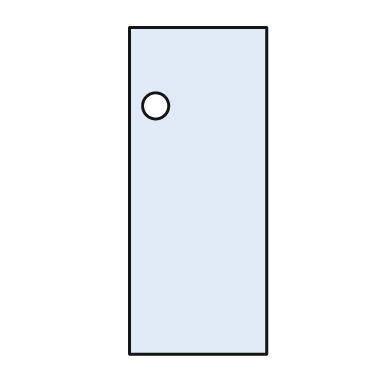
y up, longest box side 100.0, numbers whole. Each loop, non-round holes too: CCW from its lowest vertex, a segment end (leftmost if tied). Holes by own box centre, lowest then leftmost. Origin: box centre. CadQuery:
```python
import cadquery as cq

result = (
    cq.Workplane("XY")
    .moveTo(-21.0, -50.0)
    .lineTo(21.0, -50.0)
    .lineTo(21.0, 50.0)
    .lineTo(-21.0, 50.0)
    .close()
    .moveTo(-13.0, 26.0)
    .circle(4.0)
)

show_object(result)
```